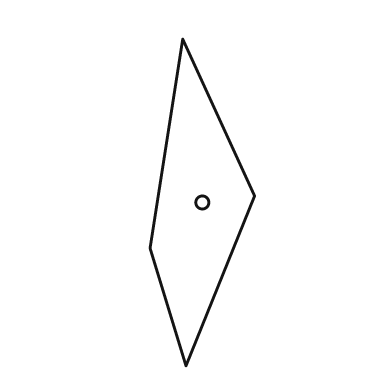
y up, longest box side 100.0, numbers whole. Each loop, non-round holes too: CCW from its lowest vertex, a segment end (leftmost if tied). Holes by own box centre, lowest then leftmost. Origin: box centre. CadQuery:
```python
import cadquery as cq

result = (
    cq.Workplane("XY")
    .moveTo(-5.0, -50.0)
    .lineTo(16.0, 2.0)
    .lineTo(-6.0, 50.0)
    .lineTo(-16.0, -14.0)
    .close()
    .moveTo(0.0, 0.0)
    .circle(2.0)
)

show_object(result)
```